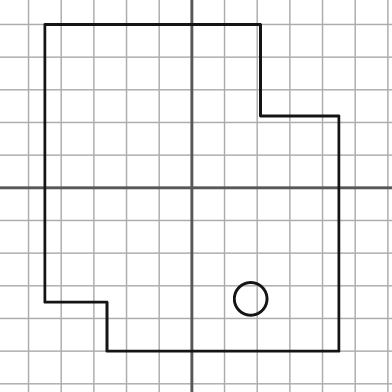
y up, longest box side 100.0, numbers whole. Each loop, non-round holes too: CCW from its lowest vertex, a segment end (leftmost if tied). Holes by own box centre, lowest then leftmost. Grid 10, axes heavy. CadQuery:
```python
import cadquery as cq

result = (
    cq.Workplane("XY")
    .moveTo(-26.0, -50.0)
    .lineTo(45.0, -50.0)
    .lineTo(45.0, 22.0)
    .lineTo(21.0, 22.0)
    .lineTo(21.0, 50.0)
    .lineTo(-45.0, 50.0)
    .lineTo(-45.0, -35.0)
    .lineTo(-26.0, -35.0)
    .close()
    .moveTo(18.0, -34.0)
    .circle(5.0)
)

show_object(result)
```